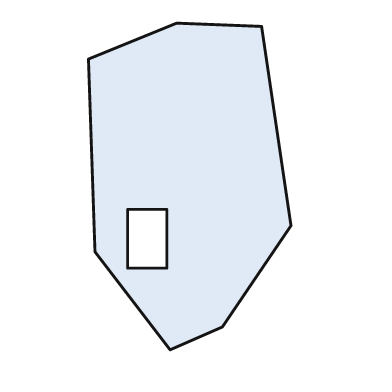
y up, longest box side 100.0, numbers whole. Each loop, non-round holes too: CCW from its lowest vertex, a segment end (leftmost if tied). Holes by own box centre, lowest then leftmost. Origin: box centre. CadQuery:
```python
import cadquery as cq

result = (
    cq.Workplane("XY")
    .moveTo(-6.0, -50.0)
    .lineTo(10.0, -43.0)
    .lineTo(31.0, -12.0)
    .lineTo(22.0, 49.0)
    .lineTo(-4.0, 50.0)
    .lineTo(-31.0, 39.0)
    .lineTo(-29.0, -20.0)
    .close()
    .moveTo(-19.0, -25.0)
    .lineTo(-7.0, -25.0)
    .lineTo(-7.0, -7.0)
    .lineTo(-19.0, -7.0)
    .close()
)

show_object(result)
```